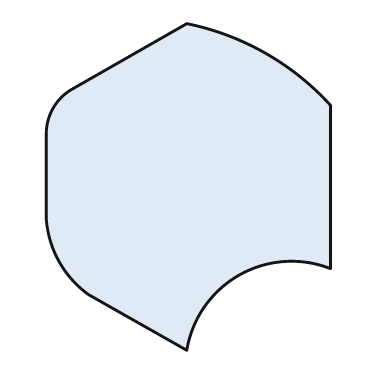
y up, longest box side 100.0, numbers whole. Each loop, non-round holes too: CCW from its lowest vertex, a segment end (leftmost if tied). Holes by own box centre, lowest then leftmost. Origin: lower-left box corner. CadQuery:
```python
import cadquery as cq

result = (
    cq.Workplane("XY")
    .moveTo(43.0, 0.0)
    .threePointArc((59.0, 23.0), (87.0, 25.0))
    .lineTo(87.0, 75.0)
    .threePointArc((67.0, 91.0), (43.0, 100.0))
    .lineTo(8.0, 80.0)
    .threePointArc((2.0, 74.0), (0.0, 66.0))
    .lineTo(0.0, 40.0)
    .threePointArc((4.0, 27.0), (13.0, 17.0))
    .close()
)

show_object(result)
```